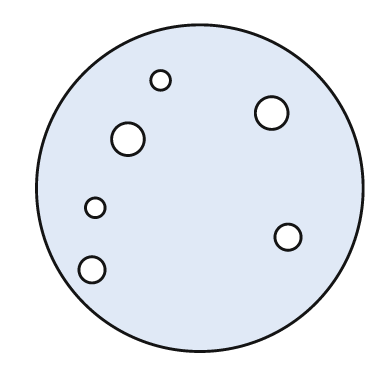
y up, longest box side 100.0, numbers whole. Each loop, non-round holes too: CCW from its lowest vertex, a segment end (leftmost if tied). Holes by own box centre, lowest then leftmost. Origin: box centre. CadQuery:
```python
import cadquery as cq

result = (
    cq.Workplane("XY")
    .moveTo(0.0, 0.0)
    .circle(50.0)
    .moveTo(-33.0, -25.0)
    .circle(4.0)
    .moveTo(27.0, -15.0)
    .circle(4.0)
    .moveTo(-32.0, -6.0)
    .circle(3.0)
    .moveTo(-22.0, 15.0)
    .circle(5.0)
    .moveTo(22.0, 23.0)
    .circle(5.0)
    .moveTo(-12.0, 33.0)
    .circle(3.0)
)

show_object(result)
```